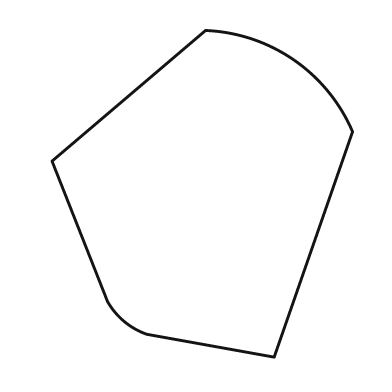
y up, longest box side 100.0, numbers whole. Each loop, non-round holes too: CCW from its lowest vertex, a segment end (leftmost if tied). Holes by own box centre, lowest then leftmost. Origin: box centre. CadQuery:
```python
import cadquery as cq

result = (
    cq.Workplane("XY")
    .moveTo(22.0, -50.0)
    .lineTo(46.0, 19.0)
    .threePointArc((28.0, 41.0), (1.0, 50.0))
    .lineTo(-46.0, 10.0)
    .lineTo(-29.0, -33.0)
    .threePointArc((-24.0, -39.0), (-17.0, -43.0))
    .close()
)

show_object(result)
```